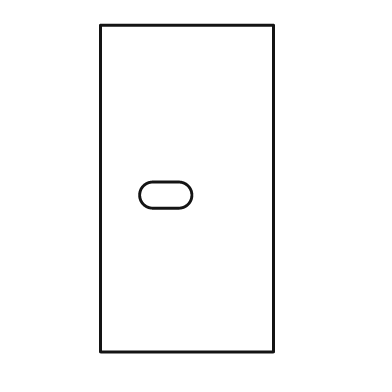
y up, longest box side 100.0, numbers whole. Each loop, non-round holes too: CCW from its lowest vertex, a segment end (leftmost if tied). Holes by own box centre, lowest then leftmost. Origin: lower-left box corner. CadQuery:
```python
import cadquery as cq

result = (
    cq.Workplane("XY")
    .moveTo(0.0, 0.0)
    .lineTo(53.0, 0.0)
    .lineTo(53.0, 100.0)
    .lineTo(0.0, 100.0)
    .close()
    .moveTo(16.0, 44.0)
    .lineTo(24.0, 44.0)
    .threePointArc((28.0, 48.0), (24.0, 52.0))
    .lineTo(16.0, 52.0)
    .threePointArc((12.0, 48.0), (16.0, 44.0))
    .close()
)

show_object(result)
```